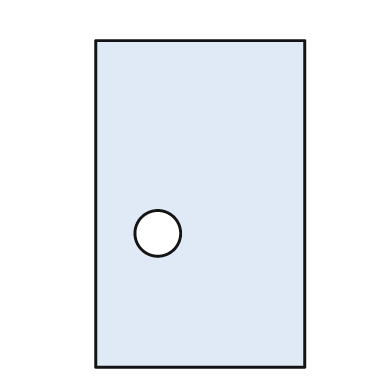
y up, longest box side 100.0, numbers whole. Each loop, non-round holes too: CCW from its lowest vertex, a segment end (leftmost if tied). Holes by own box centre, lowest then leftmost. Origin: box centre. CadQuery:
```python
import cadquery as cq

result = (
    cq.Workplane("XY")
    .moveTo(-32.0, -50.0)
    .lineTo(32.0, -50.0)
    .lineTo(32.0, 50.0)
    .lineTo(-32.0, 50.0)
    .close()
    .moveTo(-13.0, -9.0)
    .circle(7.0)
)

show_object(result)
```